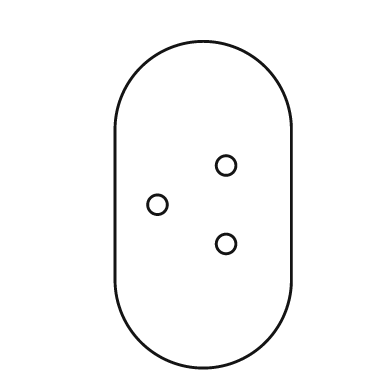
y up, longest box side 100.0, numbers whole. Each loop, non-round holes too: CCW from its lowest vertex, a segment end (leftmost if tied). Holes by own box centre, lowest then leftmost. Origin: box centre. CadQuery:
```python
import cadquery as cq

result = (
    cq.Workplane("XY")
    .moveTo(-27.0, -23.0)
    .threePointArc((0.0, -50.0), (27.0, -23.0))
    .lineTo(27.0, 23.0)
    .threePointArc((0.0, 50.0), (-27.0, 23.0))
    .close()
    .moveTo(7.0, -12.0)
    .circle(3.0)
    .moveTo(-14.0, 0.0)
    .circle(3.0)
    .moveTo(7.0, 12.0)
    .circle(3.0)
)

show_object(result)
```